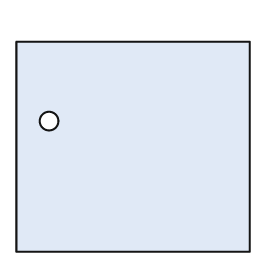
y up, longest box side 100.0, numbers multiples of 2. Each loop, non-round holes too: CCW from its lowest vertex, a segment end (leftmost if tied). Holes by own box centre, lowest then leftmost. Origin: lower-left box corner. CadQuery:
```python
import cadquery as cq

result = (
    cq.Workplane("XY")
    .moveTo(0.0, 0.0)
    .lineTo(100.0, 0.0)
    .lineTo(100.0, 90.0)
    .lineTo(0.0, 90.0)
    .close()
    .moveTo(14.0, 56.0)
    .circle(4.0)
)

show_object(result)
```